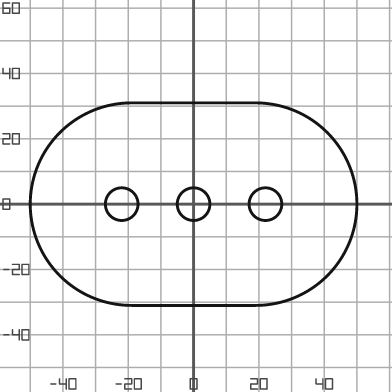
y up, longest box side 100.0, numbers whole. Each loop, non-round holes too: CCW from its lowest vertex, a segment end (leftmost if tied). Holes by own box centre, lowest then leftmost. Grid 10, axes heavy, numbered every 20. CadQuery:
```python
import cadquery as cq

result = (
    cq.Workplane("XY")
    .moveTo(-19.0, -31.0)
    .lineTo(19.0, -31.0)
    .threePointArc((50.0, 0.0), (19.0, 31.0))
    .lineTo(-19.0, 31.0)
    .threePointArc((-50.0, 0.0), (-19.0, -31.0))
    .close()
    .moveTo(-22.0, 0.0)
    .circle(5.0)
    .moveTo(0.0, 0.0)
    .circle(5.0)
    .moveTo(22.0, 0.0)
    .circle(5.0)
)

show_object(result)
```